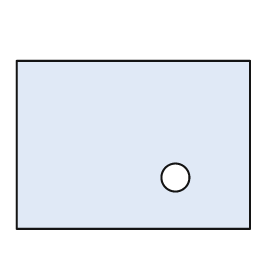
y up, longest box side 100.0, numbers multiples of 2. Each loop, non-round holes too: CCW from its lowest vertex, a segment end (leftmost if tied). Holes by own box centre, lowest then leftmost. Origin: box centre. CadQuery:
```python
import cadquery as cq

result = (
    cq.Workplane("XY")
    .moveTo(-50.0, -36.0)
    .lineTo(50.0, -36.0)
    .lineTo(50.0, 36.0)
    .lineTo(-50.0, 36.0)
    .close()
    .moveTo(18.0, -14.0)
    .circle(6.0)
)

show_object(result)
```